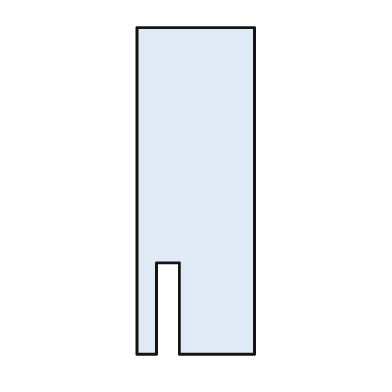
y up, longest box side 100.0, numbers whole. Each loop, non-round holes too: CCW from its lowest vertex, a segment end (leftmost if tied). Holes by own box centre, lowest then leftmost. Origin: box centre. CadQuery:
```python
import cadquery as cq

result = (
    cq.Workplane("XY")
    .moveTo(-18.0, -50.0)
    .lineTo(-12.0, -50.0)
    .lineTo(-12.0, -22.0)
    .lineTo(-5.0, -22.0)
    .lineTo(-5.0, -50.0)
    .lineTo(18.0, -50.0)
    .lineTo(18.0, 50.0)
    .lineTo(-18.0, 50.0)
    .close()
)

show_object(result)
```